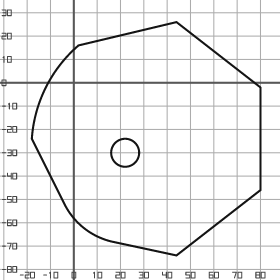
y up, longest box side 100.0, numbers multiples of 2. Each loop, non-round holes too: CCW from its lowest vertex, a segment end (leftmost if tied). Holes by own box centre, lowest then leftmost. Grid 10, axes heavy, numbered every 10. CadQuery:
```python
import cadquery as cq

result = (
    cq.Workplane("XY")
    .moveTo(44.0, -74.0)
    .lineTo(80.0, -46.0)
    .lineTo(80.0, -2.0)
    .lineTo(44.0, 26.0)
    .lineTo(2.0, 16.0)
    .threePointArc((-12.0, -2.0), (-18.0, -24.0))
    .lineTo(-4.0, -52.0)
    .threePointArc((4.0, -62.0), (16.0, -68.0))
    .close()
    .moveTo(22.0, -30.0)
    .circle(6.0)
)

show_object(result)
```